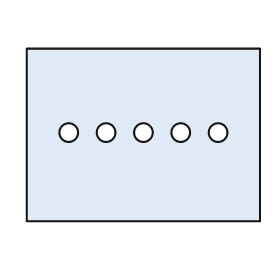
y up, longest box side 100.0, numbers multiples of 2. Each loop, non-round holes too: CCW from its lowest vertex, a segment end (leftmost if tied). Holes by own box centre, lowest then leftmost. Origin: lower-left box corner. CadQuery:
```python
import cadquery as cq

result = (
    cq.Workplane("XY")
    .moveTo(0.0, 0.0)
    .lineTo(100.0, 0.0)
    .lineTo(100.0, 74.0)
    .lineTo(0.0, 74.0)
    .close()
    .moveTo(18.0, 38.0)
    .circle(4.0)
    .moveTo(34.0, 38.0)
    .circle(4.0)
    .moveTo(50.0, 38.0)
    .circle(4.0)
    .moveTo(66.0, 38.0)
    .circle(4.0)
    .moveTo(82.0, 38.0)
    .circle(4.0)
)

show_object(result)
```